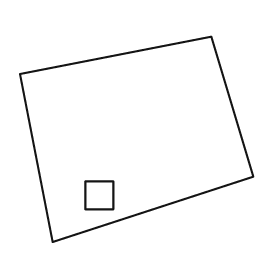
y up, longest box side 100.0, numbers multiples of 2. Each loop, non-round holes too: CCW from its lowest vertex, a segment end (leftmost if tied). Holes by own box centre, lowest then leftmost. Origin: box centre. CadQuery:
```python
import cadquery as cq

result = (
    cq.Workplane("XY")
    .moveTo(-36.0, -44.0)
    .lineTo(50.0, -16.0)
    .lineTo(32.0, 44.0)
    .lineTo(-50.0, 28.0)
    .close()
    .moveTo(-22.0, -30.0)
    .lineTo(-10.0, -30.0)
    .lineTo(-10.0, -18.0)
    .lineTo(-22.0, -18.0)
    .close()
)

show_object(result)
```